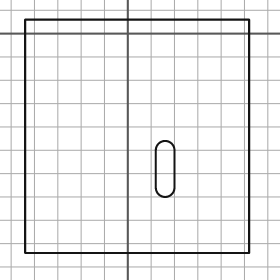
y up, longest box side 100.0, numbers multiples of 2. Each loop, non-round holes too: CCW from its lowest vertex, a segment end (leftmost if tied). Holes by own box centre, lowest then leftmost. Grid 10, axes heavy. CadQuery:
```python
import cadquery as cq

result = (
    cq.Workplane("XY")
    .moveTo(-44.0, -94.0)
    .lineTo(52.0, -94.0)
    .lineTo(52.0, 6.0)
    .lineTo(-44.0, 6.0)
    .close()
    .moveTo(12.0, -66.0)
    .threePointArc((16.0, -70.0), (20.0, -66.0))
    .lineTo(20.0, -50.0)
    .threePointArc((16.0, -46.0), (12.0, -50.0))
    .close()
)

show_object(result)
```